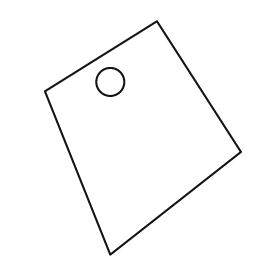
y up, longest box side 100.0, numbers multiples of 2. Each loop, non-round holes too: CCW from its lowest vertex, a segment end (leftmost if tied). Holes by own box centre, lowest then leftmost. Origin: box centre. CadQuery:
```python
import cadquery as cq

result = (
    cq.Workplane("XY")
    .moveTo(-14.0, -50.0)
    .lineTo(42.0, -6.0)
    .lineTo(6.0, 50.0)
    .lineTo(-42.0, 20.0)
    .close()
    .moveTo(-14.0, 24.0)
    .circle(6.0)
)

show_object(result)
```